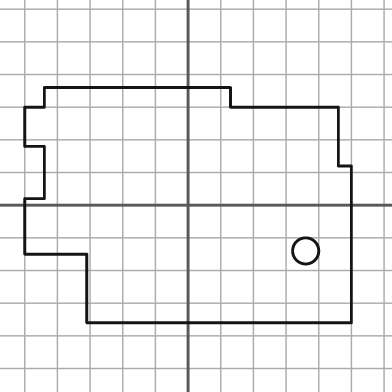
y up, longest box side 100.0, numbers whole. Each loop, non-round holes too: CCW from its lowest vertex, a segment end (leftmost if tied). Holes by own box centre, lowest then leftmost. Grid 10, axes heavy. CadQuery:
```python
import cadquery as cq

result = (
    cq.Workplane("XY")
    .moveTo(-31.0, -36.0)
    .lineTo(50.0, -36.0)
    .lineTo(50.0, 12.0)
    .lineTo(46.0, 12.0)
    .lineTo(46.0, 30.0)
    .lineTo(13.0, 30.0)
    .lineTo(13.0, 36.0)
    .lineTo(-44.0, 36.0)
    .lineTo(-44.0, 30.0)
    .lineTo(-50.0, 30.0)
    .lineTo(-50.0, 18.0)
    .lineTo(-44.0, 18.0)
    .lineTo(-44.0, 2.0)
    .lineTo(-50.0, 2.0)
    .lineTo(-50.0, -15.0)
    .lineTo(-31.0, -15.0)
    .close()
    .moveTo(36.0, -14.0)
    .circle(4.0)
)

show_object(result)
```